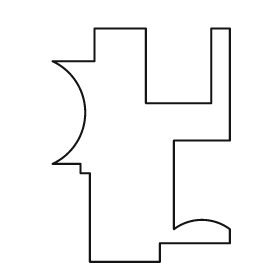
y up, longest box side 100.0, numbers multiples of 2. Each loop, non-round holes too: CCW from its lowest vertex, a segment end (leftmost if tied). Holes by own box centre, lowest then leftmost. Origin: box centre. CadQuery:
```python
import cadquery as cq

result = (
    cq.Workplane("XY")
    .moveTo(-22.0, -50.0)
    .lineTo(8.0, -50.0)
    .lineTo(8.0, -42.0)
    .lineTo(38.0, -42.0)
    .lineTo(38.0, -36.0)
    .threePointArc((26.0, -32.0), (14.0, -36.0))
    .lineTo(14.0, 2.0)
    .lineTo(38.0, 2.0)
    .lineTo(38.0, 50.0)
    .lineTo(30.0, 50.0)
    .lineTo(30.0, 18.0)
    .lineTo(2.0, 18.0)
    .lineTo(2.0, 50.0)
    .lineTo(-20.0, 50.0)
    .lineTo(-20.0, 36.0)
    .lineTo(-38.0, 36.0)
    .threePointArc((-24.0, 14.0), (-38.0, -8.0))
    .lineTo(-26.0, -8.0)
    .lineTo(-26.0, -12.0)
    .lineTo(-22.0, -12.0)
    .close()
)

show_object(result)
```